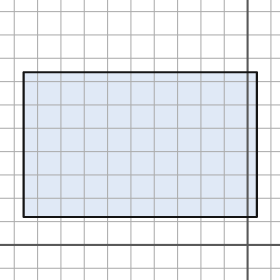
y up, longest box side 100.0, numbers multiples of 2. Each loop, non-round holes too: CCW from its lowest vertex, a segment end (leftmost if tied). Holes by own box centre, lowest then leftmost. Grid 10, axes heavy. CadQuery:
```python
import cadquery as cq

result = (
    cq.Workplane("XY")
    .moveTo(-96.0, 12.0)
    .lineTo(4.0, 12.0)
    .lineTo(4.0, 74.0)
    .lineTo(-96.0, 74.0)
    .close()
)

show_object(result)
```